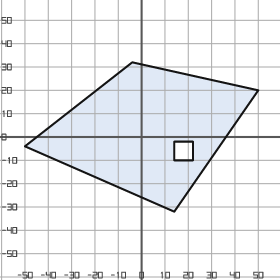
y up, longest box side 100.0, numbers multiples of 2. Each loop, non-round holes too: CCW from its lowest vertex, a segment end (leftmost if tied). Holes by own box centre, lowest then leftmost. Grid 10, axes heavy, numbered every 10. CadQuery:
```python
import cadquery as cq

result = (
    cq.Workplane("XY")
    .moveTo(14.0, -32.0)
    .lineTo(50.0, 20.0)
    .lineTo(-4.0, 32.0)
    .lineTo(-50.0, -4.0)
    .close()
    .moveTo(14.0, -10.0)
    .lineTo(22.0, -10.0)
    .lineTo(22.0, -2.0)
    .lineTo(14.0, -2.0)
    .close()
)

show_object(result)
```